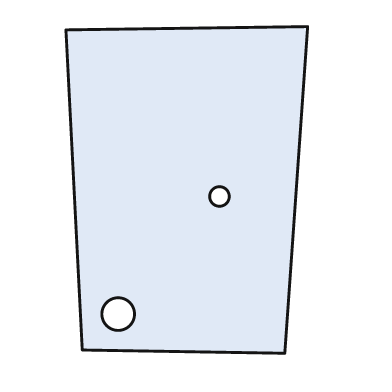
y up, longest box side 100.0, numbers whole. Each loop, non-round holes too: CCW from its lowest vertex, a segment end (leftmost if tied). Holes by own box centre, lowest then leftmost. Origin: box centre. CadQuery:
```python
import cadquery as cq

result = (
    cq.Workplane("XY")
    .moveTo(30.0, -50.0)
    .lineTo(37.0, 50.0)
    .lineTo(-37.0, 49.0)
    .lineTo(-32.0, -49.0)
    .close()
    .moveTo(-21.0, -38.0)
    .circle(5.0)
    .moveTo(10.0, -2.0)
    .circle(3.0)
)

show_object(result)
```